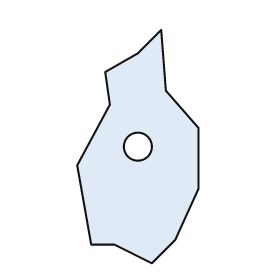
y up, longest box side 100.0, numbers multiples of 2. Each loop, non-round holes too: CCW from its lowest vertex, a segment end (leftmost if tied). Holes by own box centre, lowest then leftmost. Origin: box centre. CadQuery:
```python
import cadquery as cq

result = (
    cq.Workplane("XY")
    .moveTo(6.0, -50.0)
    .lineTo(16.0, -40.0)
    .lineTo(26.0, -18.0)
    .lineTo(26.0, 8.0)
    .lineTo(12.0, 24.0)
    .lineTo(10.0, 50.0)
    .lineTo(0.0, 40.0)
    .lineTo(-14.0, 32.0)
    .lineTo(-12.0, 18.0)
    .lineTo(-26.0, -8.0)
    .lineTo(-20.0, -42.0)
    .lineTo(-10.0, -42.0)
    .close()
    .moveTo(0.0, 0.0)
    .circle(6.0)
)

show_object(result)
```